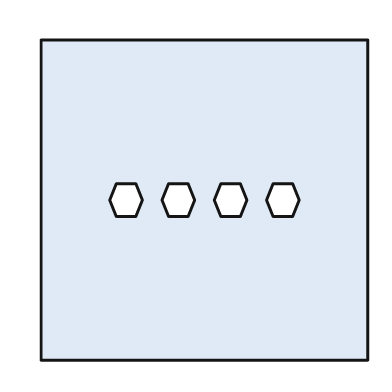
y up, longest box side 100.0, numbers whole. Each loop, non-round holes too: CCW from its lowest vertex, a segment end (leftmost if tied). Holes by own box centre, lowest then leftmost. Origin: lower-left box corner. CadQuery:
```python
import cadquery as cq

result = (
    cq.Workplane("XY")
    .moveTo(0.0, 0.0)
    .lineTo(100.0, 0.0)
    .lineTo(100.0, 98.0)
    .lineTo(0.0, 98.0)
    .close()
    .moveTo(23.0, 44.0)
    .lineTo(29.0, 44.0)
    .lineTo(31.0, 49.0)
    .lineTo(29.0, 54.0)
    .lineTo(23.0, 54.0)
    .lineTo(21.0, 49.0)
    .close()
    .moveTo(39.0, 44.0)
    .lineTo(45.0, 44.0)
    .lineTo(47.0, 49.0)
    .lineTo(45.0, 54.0)
    .lineTo(39.0, 54.0)
    .lineTo(37.0, 49.0)
    .close()
    .moveTo(55.0, 44.0)
    .lineTo(61.0, 44.0)
    .lineTo(63.0, 49.0)
    .lineTo(61.0, 54.0)
    .lineTo(55.0, 54.0)
    .lineTo(53.0, 49.0)
    .close()
    .moveTo(71.0, 44.0)
    .lineTo(77.0, 44.0)
    .lineTo(79.0, 49.0)
    .lineTo(77.0, 54.0)
    .lineTo(71.0, 54.0)
    .lineTo(69.0, 49.0)
    .close()
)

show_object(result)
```